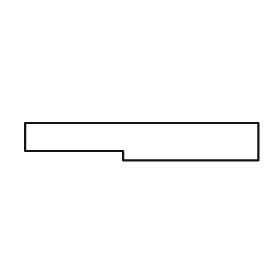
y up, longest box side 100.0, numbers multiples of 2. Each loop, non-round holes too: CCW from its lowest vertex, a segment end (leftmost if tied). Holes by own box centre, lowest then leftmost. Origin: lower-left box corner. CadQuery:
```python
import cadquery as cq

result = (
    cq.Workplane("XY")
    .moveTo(42.0, 0.0)
    .lineTo(100.0, 0.0)
    .lineTo(100.0, 16.0)
    .lineTo(0.0, 16.0)
    .lineTo(0.0, 4.0)
    .lineTo(42.0, 4.0)
    .close()
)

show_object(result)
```